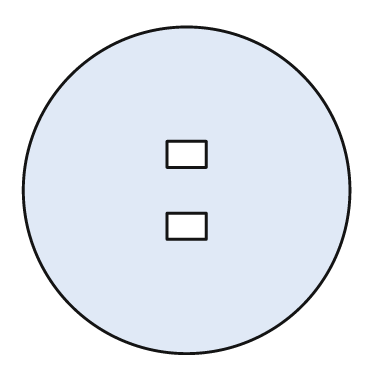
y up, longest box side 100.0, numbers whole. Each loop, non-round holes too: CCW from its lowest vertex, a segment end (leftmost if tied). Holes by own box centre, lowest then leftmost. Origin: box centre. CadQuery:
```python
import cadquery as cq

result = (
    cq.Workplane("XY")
    .moveTo(0.0, 0.0)
    .circle(50.0)
    .moveTo(-6.0, -15.0)
    .lineTo(6.0, -15.0)
    .lineTo(6.0, -7.0)
    .lineTo(-6.0, -7.0)
    .close()
    .moveTo(-6.0, 7.0)
    .lineTo(6.0, 7.0)
    .lineTo(6.0, 15.0)
    .lineTo(-6.0, 15.0)
    .close()
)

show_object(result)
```